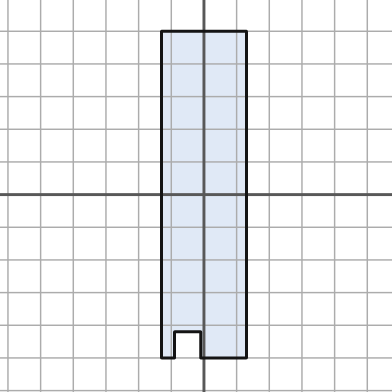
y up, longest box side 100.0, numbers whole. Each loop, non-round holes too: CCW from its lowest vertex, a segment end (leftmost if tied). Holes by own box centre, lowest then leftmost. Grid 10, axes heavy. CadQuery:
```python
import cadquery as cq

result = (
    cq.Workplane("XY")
    .moveTo(-13.0, -50.0)
    .lineTo(-9.0, -50.0)
    .lineTo(-9.0, -42.0)
    .lineTo(-1.0, -42.0)
    .lineTo(-1.0, -50.0)
    .lineTo(13.0, -50.0)
    .lineTo(13.0, 50.0)
    .lineTo(-13.0, 50.0)
    .close()
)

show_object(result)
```